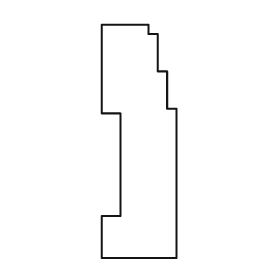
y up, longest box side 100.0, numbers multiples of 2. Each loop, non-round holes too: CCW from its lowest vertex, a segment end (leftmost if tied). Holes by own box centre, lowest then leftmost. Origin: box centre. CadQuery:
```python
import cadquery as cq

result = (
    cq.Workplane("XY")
    .moveTo(-16.0, -50.0)
    .lineTo(16.0, -50.0)
    .lineTo(16.0, 14.0)
    .lineTo(12.0, 14.0)
    .lineTo(12.0, 30.0)
    .lineTo(8.0, 30.0)
    .lineTo(8.0, 46.0)
    .lineTo(4.0, 46.0)
    .lineTo(4.0, 50.0)
    .lineTo(-16.0, 50.0)
    .lineTo(-16.0, 12.0)
    .lineTo(-8.0, 12.0)
    .lineTo(-8.0, -32.0)
    .lineTo(-16.0, -32.0)
    .close()
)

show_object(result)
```